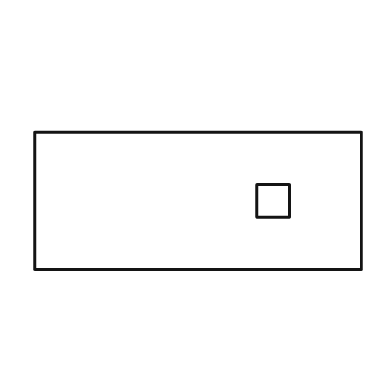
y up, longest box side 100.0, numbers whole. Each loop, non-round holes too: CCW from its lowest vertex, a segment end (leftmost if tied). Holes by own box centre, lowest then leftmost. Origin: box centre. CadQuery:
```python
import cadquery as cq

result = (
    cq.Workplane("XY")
    .moveTo(-50.0, -21.0)
    .lineTo(50.0, -21.0)
    .lineTo(50.0, 21.0)
    .lineTo(-50.0, 21.0)
    .close()
    .moveTo(18.0, -5.0)
    .lineTo(28.0, -5.0)
    .lineTo(28.0, 5.0)
    .lineTo(18.0, 5.0)
    .close()
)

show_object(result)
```